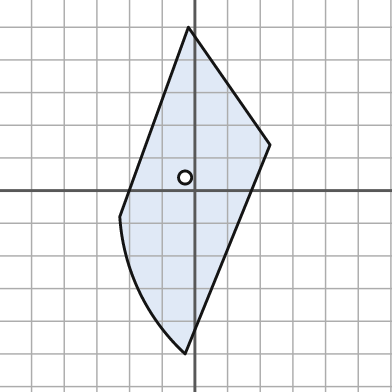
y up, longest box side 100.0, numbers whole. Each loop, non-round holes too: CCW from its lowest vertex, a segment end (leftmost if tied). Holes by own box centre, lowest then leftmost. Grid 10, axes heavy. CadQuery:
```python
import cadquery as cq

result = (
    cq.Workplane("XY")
    .moveTo(-3.0, -50.0)
    .lineTo(23.0, 14.0)
    .lineTo(-2.0, 50.0)
    .lineTo(-23.0, -8.0)
    .threePointArc((-17.0, -31.0), (-3.0, -50.0))
    .close()
    .moveTo(-3.0, 4.0)
    .circle(2.0)
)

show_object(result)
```